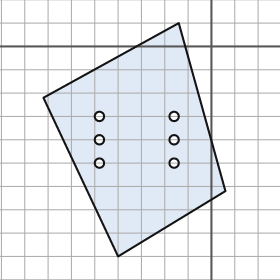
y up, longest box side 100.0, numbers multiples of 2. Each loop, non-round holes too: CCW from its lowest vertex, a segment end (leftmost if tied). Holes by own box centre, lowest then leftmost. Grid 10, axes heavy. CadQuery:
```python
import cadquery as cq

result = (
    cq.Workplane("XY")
    .moveTo(-40.0, -90.0)
    .lineTo(6.0, -62.0)
    .lineTo(-14.0, 10.0)
    .lineTo(-72.0, -22.0)
    .close()
    .moveTo(-48.0, -50.0)
    .circle(2.0)
    .moveTo(-16.0, -50.0)
    .circle(2.0)
    .moveTo(-48.0, -40.0)
    .circle(2.0)
    .moveTo(-16.0, -40.0)
    .circle(2.0)
    .moveTo(-48.0, -30.0)
    .circle(2.0)
    .moveTo(-16.0, -30.0)
    .circle(2.0)
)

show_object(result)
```